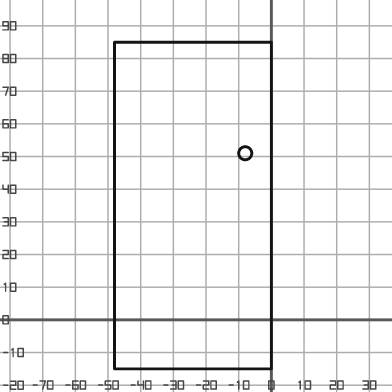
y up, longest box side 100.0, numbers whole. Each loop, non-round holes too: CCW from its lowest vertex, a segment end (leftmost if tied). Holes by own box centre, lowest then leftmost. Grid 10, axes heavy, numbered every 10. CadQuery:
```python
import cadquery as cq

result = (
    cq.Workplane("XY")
    .moveTo(-48.0, -15.0)
    .lineTo(0.0, -15.0)
    .lineTo(0.0, 85.0)
    .lineTo(-48.0, 85.0)
    .close()
    .moveTo(-8.0, 51.0)
    .circle(2.0)
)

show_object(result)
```